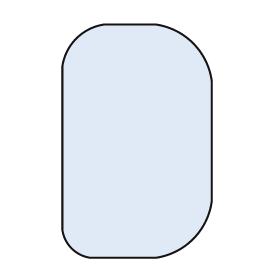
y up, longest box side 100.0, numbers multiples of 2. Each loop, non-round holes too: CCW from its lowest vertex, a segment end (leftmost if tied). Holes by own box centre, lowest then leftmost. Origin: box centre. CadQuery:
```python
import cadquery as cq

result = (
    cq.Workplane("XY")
    .moveTo(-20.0, -50.0)
    .lineTo(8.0, -50.0)
    .threePointArc((24.0, -42.0), (32.0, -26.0))
    .lineTo(32.0, 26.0)
    .threePointArc((24.0, 42.0), (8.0, 50.0))
    .lineTo(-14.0, 50.0)
    .threePointArc((-26.0, 44.0), (-32.0, 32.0))
    .lineTo(-32.0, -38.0)
    .threePointArc((-28.0, -46.0), (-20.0, -50.0))
    .close()
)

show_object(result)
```